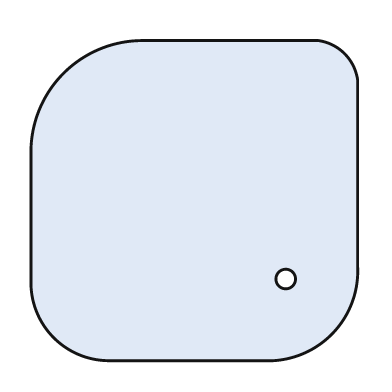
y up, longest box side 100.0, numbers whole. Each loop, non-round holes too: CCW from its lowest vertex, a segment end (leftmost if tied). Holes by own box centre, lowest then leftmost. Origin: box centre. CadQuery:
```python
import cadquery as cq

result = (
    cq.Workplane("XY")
    .moveTo(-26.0, -49.0)
    .lineTo(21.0, -49.0)
    .threePointArc((42.0, -41.0), (50.0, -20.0))
    .lineTo(50.0, 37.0)
    .threePointArc((46.0, 45.0), (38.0, 49.0))
    .lineTo(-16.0, 49.0)
    .threePointArc((-40.0, 39.0), (-50.0, 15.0))
    .lineTo(-50.0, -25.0)
    .threePointArc((-43.0, -42.0), (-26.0, -49.0))
    .close()
    .moveTo(28.0, -24.0)
    .circle(3.0)
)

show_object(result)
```